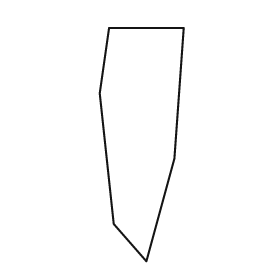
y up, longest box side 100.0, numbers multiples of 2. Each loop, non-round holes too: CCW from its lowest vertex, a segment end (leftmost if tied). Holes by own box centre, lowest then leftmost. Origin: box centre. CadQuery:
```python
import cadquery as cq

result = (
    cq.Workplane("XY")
    .moveTo(2.0, -50.0)
    .lineTo(14.0, -6.0)
    .lineTo(18.0, 50.0)
    .lineTo(-14.0, 50.0)
    .lineTo(-18.0, 22.0)
    .lineTo(-12.0, -34.0)
    .close()
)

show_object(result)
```